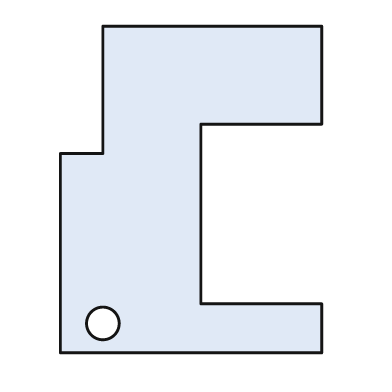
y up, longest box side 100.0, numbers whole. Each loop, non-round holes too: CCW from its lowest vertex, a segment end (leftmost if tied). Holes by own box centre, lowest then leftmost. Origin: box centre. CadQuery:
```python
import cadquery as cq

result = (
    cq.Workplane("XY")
    .moveTo(-40.0, -50.0)
    .lineTo(40.0, -50.0)
    .lineTo(40.0, -35.0)
    .lineTo(3.0, -35.0)
    .lineTo(3.0, 20.0)
    .lineTo(40.0, 20.0)
    .lineTo(40.0, 50.0)
    .lineTo(-27.0, 50.0)
    .lineTo(-27.0, 11.0)
    .lineTo(-40.0, 11.0)
    .close()
    .moveTo(-27.0, -41.0)
    .circle(5.0)
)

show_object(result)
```